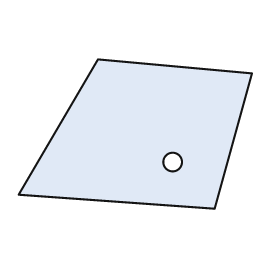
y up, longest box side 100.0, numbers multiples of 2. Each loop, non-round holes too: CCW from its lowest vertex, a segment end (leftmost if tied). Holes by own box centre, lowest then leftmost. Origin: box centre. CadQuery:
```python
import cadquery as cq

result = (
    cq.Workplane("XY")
    .moveTo(34.0, -32.0)
    .lineTo(50.0, 26.0)
    .lineTo(-16.0, 32.0)
    .lineTo(-50.0, -26.0)
    .close()
    .moveTo(16.0, -12.0)
    .circle(4.0)
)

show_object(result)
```